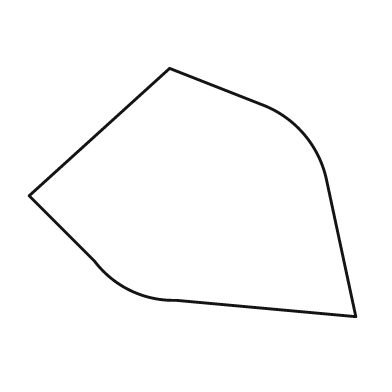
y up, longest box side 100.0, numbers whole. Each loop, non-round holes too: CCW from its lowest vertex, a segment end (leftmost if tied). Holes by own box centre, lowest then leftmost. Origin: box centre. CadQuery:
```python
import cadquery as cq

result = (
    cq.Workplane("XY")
    .moveTo(50.0, -38.0)
    .lineTo(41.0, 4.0)
    .threePointArc((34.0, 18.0), (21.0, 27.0))
    .lineTo(-7.0, 38.0)
    .lineTo(-50.0, -1.0)
    .lineTo(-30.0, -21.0)
    .threePointArc((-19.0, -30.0), (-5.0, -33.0))
    .close()
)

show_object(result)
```